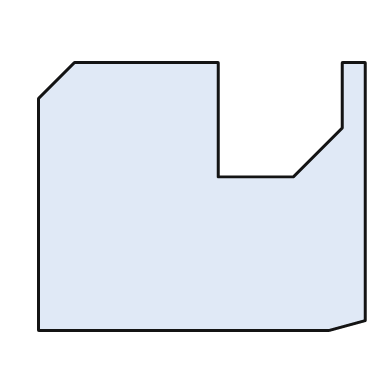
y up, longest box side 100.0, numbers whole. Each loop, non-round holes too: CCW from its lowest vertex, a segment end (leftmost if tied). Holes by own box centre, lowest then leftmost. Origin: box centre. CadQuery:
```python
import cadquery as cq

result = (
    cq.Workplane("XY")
    .moveTo(-50.0, -41.0)
    .lineTo(39.0, -41.0)
    .lineTo(50.0, -38.0)
    .lineTo(50.0, 41.0)
    .lineTo(43.0, 41.0)
    .lineTo(43.0, 21.0)
    .lineTo(28.0, 6.0)
    .lineTo(5.0, 6.0)
    .lineTo(5.0, 41.0)
    .lineTo(-39.0, 41.0)
    .lineTo(-50.0, 30.0)
    .close()
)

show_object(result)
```